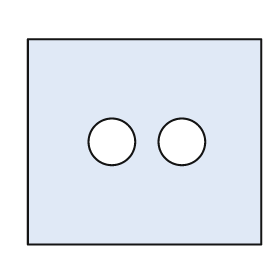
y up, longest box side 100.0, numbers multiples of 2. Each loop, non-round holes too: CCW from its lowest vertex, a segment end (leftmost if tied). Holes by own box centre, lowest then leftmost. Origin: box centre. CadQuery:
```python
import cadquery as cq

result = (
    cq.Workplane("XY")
    .moveTo(-50.0, -44.0)
    .lineTo(50.0, -44.0)
    .lineTo(50.0, 44.0)
    .lineTo(-50.0, 44.0)
    .close()
    .moveTo(-14.0, 0.0)
    .circle(10.0)
    .moveTo(16.0, 0.0)
    .circle(10.0)
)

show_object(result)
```